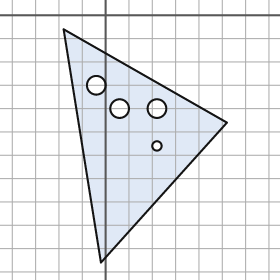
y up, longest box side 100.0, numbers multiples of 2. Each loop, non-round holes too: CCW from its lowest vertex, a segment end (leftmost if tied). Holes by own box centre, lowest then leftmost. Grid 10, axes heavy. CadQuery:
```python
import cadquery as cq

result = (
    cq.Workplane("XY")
    .moveTo(-2.0, -106.0)
    .lineTo(52.0, -46.0)
    .lineTo(-18.0, -6.0)
    .close()
    .moveTo(22.0, -56.0)
    .circle(2.0)
    .moveTo(6.0, -40.0)
    .circle(4.0)
    .moveTo(22.0, -40.0)
    .circle(4.0)
    .moveTo(-4.0, -30.0)
    .circle(4.0)
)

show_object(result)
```